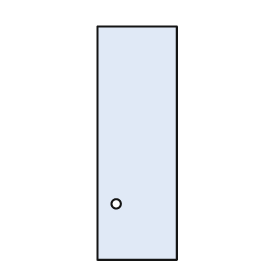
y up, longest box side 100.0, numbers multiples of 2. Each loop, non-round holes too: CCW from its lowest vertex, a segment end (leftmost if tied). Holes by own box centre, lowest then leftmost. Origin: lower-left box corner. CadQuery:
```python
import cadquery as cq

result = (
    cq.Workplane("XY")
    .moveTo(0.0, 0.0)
    .lineTo(34.0, 0.0)
    .lineTo(34.0, 100.0)
    .lineTo(0.0, 100.0)
    .close()
    .moveTo(8.0, 24.0)
    .circle(2.0)
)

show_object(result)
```